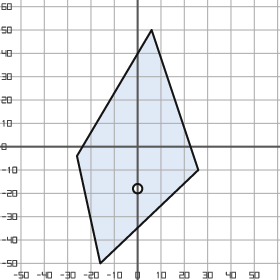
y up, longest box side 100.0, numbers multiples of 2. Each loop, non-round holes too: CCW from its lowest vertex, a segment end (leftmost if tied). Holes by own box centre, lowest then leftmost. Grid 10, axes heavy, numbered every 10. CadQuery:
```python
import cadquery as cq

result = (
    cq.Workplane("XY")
    .moveTo(-16.0, -50.0)
    .lineTo(26.0, -10.0)
    .lineTo(6.0, 50.0)
    .lineTo(-26.0, -4.0)
    .close()
    .moveTo(0.0, -18.0)
    .circle(2.0)
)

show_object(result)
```